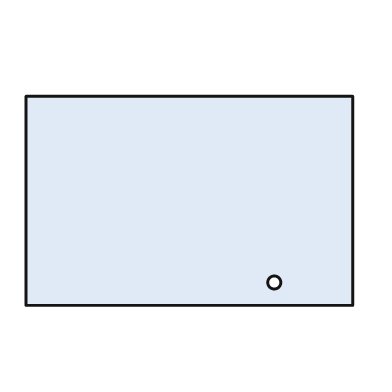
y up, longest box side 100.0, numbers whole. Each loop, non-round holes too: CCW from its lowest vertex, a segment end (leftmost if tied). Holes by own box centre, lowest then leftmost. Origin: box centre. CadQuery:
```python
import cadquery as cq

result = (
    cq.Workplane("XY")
    .moveTo(-50.0, -32.0)
    .lineTo(50.0, -32.0)
    .lineTo(50.0, 32.0)
    .lineTo(-50.0, 32.0)
    .close()
    .moveTo(26.0, -25.0)
    .circle(2.0)
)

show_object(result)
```